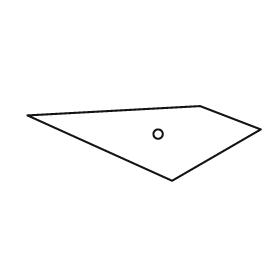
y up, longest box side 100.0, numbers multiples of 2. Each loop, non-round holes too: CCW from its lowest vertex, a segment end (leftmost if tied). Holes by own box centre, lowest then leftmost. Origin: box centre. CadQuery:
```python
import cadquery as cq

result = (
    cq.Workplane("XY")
    .moveTo(12.0, -16.0)
    .lineTo(50.0, 6.0)
    .lineTo(24.0, 16.0)
    .lineTo(-50.0, 12.0)
    .close()
    .moveTo(6.0, 4.0)
    .circle(2.0)
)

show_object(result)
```